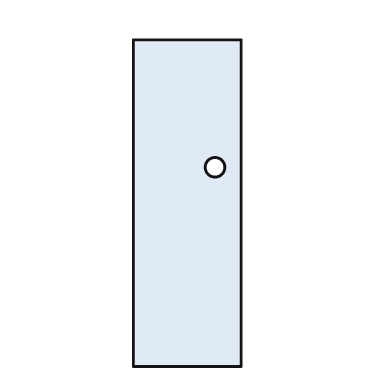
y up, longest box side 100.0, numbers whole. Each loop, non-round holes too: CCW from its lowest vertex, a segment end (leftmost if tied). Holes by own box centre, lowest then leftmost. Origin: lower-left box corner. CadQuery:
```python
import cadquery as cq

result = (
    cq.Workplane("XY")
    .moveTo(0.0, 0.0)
    .lineTo(33.0, 0.0)
    .lineTo(33.0, 100.0)
    .lineTo(0.0, 100.0)
    .close()
    .moveTo(25.0, 61.0)
    .circle(3.0)
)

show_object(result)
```